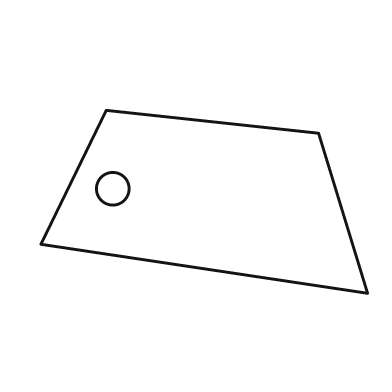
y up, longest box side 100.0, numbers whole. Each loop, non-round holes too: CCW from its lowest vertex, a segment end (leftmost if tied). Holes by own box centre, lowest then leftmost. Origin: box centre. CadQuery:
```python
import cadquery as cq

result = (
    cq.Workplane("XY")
    .moveTo(50.0, -28.0)
    .lineTo(35.0, 21.0)
    .lineTo(-30.0, 28.0)
    .lineTo(-50.0, -13.0)
    .close()
    .moveTo(-28.0, 4.0)
    .circle(5.0)
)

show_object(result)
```